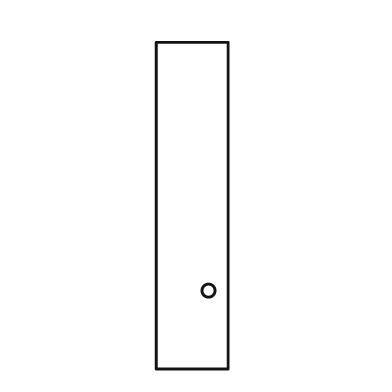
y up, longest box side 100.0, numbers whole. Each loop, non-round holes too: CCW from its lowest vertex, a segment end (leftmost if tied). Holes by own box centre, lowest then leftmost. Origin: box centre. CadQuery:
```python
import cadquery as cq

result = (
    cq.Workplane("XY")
    .moveTo(-11.0, -50.0)
    .lineTo(11.0, -50.0)
    .lineTo(11.0, 50.0)
    .lineTo(-11.0, 50.0)
    .close()
    .moveTo(5.0, -26.0)
    .circle(2.0)
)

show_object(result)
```